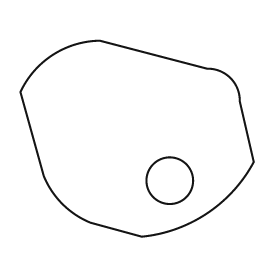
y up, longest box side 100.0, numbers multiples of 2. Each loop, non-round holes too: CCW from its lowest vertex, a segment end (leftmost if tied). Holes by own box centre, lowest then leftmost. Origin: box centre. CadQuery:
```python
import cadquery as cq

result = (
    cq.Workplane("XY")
    .moveTo(2.0, -42.0)
    .threePointArc((30.0, -32.0), (50.0, -10.0))
    .lineTo(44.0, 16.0)
    .threePointArc((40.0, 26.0), (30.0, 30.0))
    .lineTo(-16.0, 42.0)
    .threePointArc((-36.0, 36.0), (-50.0, 20.0))
    .lineTo(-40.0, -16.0)
    .threePointArc((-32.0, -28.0), (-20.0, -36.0))
    .close()
    .moveTo(14.0, -18.0)
    .circle(10.0)
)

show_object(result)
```